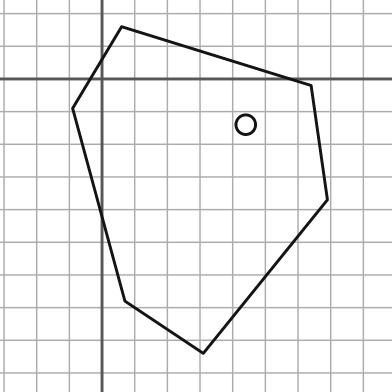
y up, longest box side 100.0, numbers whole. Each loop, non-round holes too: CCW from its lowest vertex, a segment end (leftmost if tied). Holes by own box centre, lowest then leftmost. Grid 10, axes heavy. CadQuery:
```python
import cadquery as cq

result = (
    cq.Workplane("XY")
    .moveTo(31.0, -84.0)
    .lineTo(69.0, -37.0)
    .lineTo(64.0, -2.0)
    .lineTo(6.0, 16.0)
    .lineTo(-9.0, -9.0)
    .lineTo(7.0, -68.0)
    .close()
    .moveTo(44.0, -14.0)
    .circle(3.0)
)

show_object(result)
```